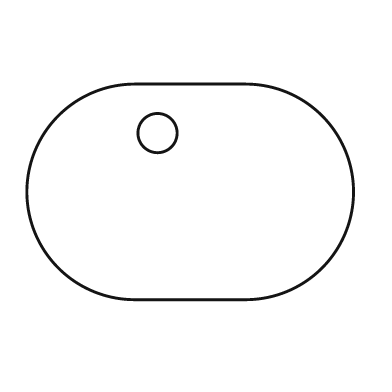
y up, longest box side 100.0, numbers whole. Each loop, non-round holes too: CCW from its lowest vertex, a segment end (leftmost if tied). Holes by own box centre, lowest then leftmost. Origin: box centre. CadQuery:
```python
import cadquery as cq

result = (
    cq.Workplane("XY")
    .moveTo(-17.0, -33.0)
    .lineTo(17.0, -33.0)
    .threePointArc((50.0, 0.0), (17.0, 33.0))
    .lineTo(-17.0, 33.0)
    .threePointArc((-50.0, 0.0), (-17.0, -33.0))
    .close()
    .moveTo(-10.0, 18.0)
    .circle(6.0)
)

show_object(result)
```